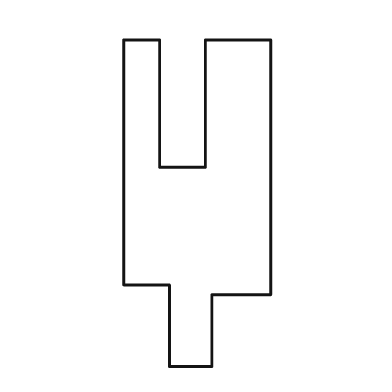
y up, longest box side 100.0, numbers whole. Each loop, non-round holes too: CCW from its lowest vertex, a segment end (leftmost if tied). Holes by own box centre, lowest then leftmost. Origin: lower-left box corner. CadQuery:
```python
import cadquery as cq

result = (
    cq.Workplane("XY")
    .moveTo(14.0, 0.0)
    .lineTo(27.0, 0.0)
    .lineTo(27.0, 22.0)
    .lineTo(45.0, 22.0)
    .lineTo(45.0, 100.0)
    .lineTo(25.0, 100.0)
    .lineTo(25.0, 61.0)
    .lineTo(11.0, 61.0)
    .lineTo(11.0, 100.0)
    .lineTo(0.0, 100.0)
    .lineTo(0.0, 25.0)
    .lineTo(14.0, 25.0)
    .close()
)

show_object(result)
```